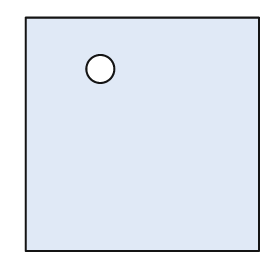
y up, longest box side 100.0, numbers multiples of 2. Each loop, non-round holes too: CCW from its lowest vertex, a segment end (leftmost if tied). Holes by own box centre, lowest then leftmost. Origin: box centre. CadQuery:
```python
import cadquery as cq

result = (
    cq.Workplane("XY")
    .moveTo(-50.0, -50.0)
    .lineTo(50.0, -50.0)
    .lineTo(50.0, 50.0)
    .lineTo(-50.0, 50.0)
    .close()
    .moveTo(-18.0, 28.0)
    .circle(6.0)
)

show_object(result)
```